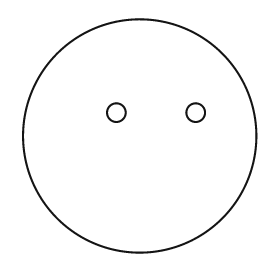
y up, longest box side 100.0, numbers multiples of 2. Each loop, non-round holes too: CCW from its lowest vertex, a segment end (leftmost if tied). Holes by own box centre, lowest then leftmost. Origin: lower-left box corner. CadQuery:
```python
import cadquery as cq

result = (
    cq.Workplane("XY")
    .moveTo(50.0, 50.0)
    .circle(50.0)
    .moveTo(40.0, 60.0)
    .circle(4.0)
    .moveTo(74.0, 60.0)
    .circle(4.0)
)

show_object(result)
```